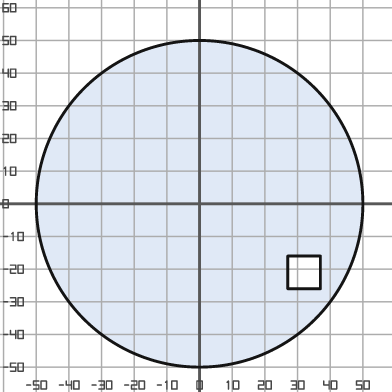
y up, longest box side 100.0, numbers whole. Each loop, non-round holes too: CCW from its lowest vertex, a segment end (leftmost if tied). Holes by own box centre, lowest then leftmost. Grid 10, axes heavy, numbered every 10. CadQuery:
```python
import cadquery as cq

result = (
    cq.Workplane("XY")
    .moveTo(0.0, 0.0)
    .circle(50.0)
    .moveTo(27.0, -26.0)
    .lineTo(37.0, -26.0)
    .lineTo(37.0, -16.0)
    .lineTo(27.0, -16.0)
    .close()
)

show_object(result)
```